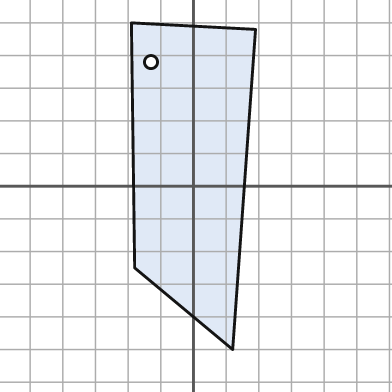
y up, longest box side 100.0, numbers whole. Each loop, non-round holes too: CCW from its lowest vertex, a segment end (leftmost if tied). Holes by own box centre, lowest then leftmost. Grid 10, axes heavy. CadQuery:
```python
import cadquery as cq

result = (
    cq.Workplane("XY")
    .moveTo(12.0, -50.0)
    .lineTo(19.0, 48.0)
    .lineTo(-19.0, 50.0)
    .lineTo(-18.0, -25.0)
    .close()
    .moveTo(-13.0, 38.0)
    .circle(2.0)
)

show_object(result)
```